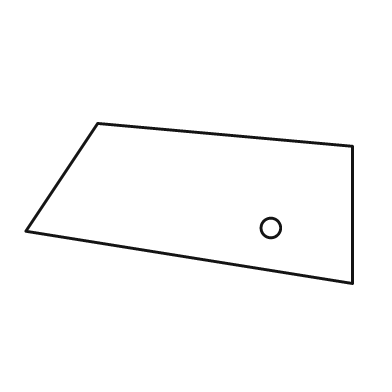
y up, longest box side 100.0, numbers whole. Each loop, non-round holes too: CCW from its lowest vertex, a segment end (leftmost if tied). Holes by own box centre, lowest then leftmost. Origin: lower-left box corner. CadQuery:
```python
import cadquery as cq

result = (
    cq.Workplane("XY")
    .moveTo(100.0, 0.0)
    .lineTo(100.0, 42.0)
    .lineTo(22.0, 49.0)
    .lineTo(0.0, 16.0)
    .close()
    .moveTo(75.0, 17.0)
    .circle(3.0)
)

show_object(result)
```